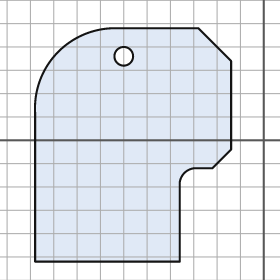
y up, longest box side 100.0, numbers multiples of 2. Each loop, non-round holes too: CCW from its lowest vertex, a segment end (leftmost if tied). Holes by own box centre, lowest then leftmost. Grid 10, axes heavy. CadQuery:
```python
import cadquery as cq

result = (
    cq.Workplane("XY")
    .moveTo(-98.0, -52.0)
    .lineTo(-36.0, -52.0)
    .lineTo(-36.0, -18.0)
    .threePointArc((-34.0, -14.0), (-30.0, -12.0))
    .lineTo(-22.0, -12.0)
    .lineTo(-14.0, -4.0)
    .lineTo(-14.0, 34.0)
    .lineTo(-28.0, 48.0)
    .lineTo(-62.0, 48.0)
    .threePointArc((-88.0, 38.0), (-98.0, 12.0))
    .close()
    .moveTo(-60.0, 36.0)
    .circle(4.0)
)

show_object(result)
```